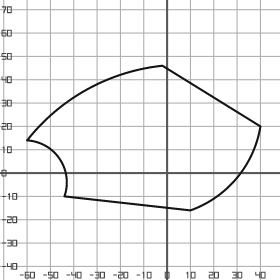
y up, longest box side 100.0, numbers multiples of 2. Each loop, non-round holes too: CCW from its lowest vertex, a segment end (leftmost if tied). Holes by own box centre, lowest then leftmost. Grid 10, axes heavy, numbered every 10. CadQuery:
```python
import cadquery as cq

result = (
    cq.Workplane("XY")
    .moveTo(10.0, -16.0)
    .threePointArc((30.0, -2.0), (40.0, 20.0))
    .lineTo(-2.0, 46.0)
    .threePointArc((-34.0, 36.0), (-60.0, 14.0))
    .threePointArc((-46.0, 6.0), (-44.0, -10.0))
    .close()
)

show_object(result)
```